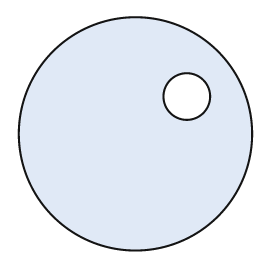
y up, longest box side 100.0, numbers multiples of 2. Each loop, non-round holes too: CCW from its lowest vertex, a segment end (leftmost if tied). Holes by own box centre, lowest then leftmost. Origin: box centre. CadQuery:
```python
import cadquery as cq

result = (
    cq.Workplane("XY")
    .moveTo(0.0, 0.0)
    .circle(50.0)
    .moveTo(22.0, 16.0)
    .circle(10.0)
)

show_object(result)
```